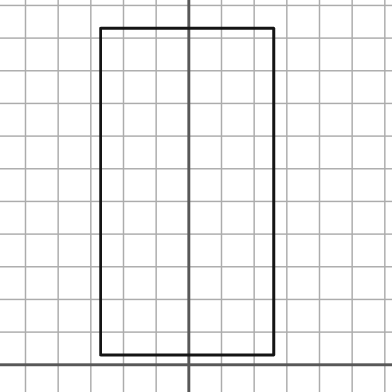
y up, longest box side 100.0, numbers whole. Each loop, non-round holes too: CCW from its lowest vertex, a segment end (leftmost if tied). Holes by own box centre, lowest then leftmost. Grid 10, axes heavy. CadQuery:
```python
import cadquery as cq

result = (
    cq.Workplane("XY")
    .moveTo(-27.0, 3.0)
    .lineTo(26.0, 3.0)
    .lineTo(26.0, 103.0)
    .lineTo(-27.0, 103.0)
    .close()
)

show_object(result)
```